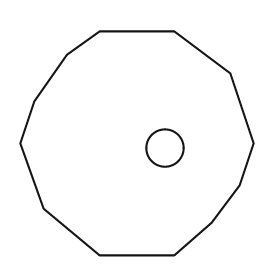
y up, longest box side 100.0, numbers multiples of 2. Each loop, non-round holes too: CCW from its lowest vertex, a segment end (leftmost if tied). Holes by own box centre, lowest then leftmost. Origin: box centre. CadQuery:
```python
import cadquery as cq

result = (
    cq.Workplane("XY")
    .moveTo(-16.0, -48.0)
    .lineTo(16.0, -48.0)
    .lineTo(32.0, -34.0)
    .lineTo(44.0, -18.0)
    .lineTo(50.0, 0.0)
    .lineTo(40.0, 30.0)
    .lineTo(16.0, 48.0)
    .lineTo(-16.0, 48.0)
    .lineTo(-30.0, 38.0)
    .lineTo(-44.0, 18.0)
    .lineTo(-50.0, 0.0)
    .lineTo(-40.0, -28.0)
    .close()
    .moveTo(12.0, -2.0)
    .circle(8.0)
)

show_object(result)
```